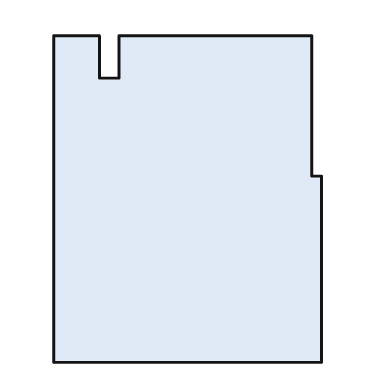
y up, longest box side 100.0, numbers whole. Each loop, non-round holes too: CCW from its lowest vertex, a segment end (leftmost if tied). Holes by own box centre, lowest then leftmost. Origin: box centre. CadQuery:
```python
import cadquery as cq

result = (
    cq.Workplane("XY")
    .moveTo(-41.0, -50.0)
    .lineTo(41.0, -50.0)
    .lineTo(41.0, 7.0)
    .lineTo(38.0, 7.0)
    .lineTo(38.0, 50.0)
    .lineTo(-21.0, 50.0)
    .lineTo(-21.0, 37.0)
    .lineTo(-27.0, 37.0)
    .lineTo(-27.0, 50.0)
    .lineTo(-41.0, 50.0)
    .close()
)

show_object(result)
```